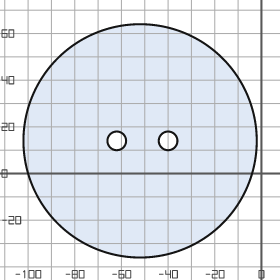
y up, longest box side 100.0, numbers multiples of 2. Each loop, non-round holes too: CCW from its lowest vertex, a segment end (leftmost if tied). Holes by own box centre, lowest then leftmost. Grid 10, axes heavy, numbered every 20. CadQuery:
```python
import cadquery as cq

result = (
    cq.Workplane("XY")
    .moveTo(-52.0, 14.0)
    .circle(50.0)
    .moveTo(-62.0, 14.0)
    .circle(4.0)
    .moveTo(-40.0, 14.0)
    .circle(4.0)
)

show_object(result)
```